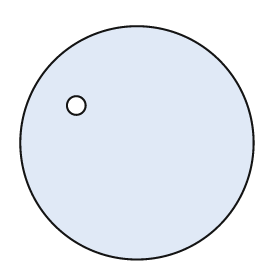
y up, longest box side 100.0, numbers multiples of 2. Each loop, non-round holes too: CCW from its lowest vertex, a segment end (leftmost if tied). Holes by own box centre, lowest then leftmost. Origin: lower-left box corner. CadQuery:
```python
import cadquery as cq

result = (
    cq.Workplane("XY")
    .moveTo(50.0, 50.0)
    .circle(50.0)
    .moveTo(24.0, 66.0)
    .circle(4.0)
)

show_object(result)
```